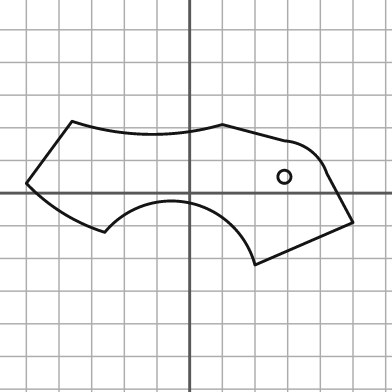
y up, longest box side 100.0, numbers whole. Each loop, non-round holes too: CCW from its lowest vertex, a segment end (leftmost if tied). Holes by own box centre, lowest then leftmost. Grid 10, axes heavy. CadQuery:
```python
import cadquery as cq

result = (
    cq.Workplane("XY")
    .moveTo(20.0, -22.0)
    .lineTo(50.0, -9.0)
    .lineTo(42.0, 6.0)
    .threePointArc((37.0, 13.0), (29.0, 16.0))
    .lineTo(10.0, 21.0)
    .threePointArc((-13.0, 18.0), (-36.0, 22.0))
    .lineTo(-50.0, 3.0)
    .threePointArc((-39.0, -6.0), (-26.0, -12.0))
    .threePointArc((0.0, -3.0), (20.0, -22.0))
    .close()
    .moveTo(29.0, 5.0)
    .circle(2.0)
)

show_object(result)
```